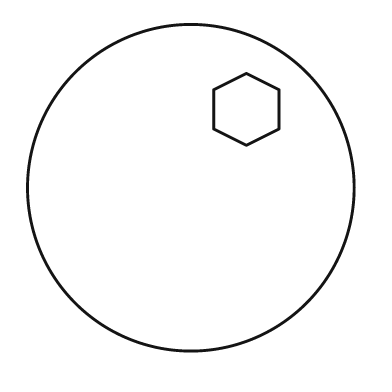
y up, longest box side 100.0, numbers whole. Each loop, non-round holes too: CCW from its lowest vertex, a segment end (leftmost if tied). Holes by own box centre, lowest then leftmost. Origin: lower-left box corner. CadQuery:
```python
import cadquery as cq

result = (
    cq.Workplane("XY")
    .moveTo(50.0, 50.0)
    .circle(50.0)
    .moveTo(67.0, 63.0)
    .lineTo(77.0, 68.0)
    .lineTo(77.0, 80.0)
    .lineTo(67.0, 85.0)
    .lineTo(57.0, 80.0)
    .lineTo(57.0, 68.0)
    .close()
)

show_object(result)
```